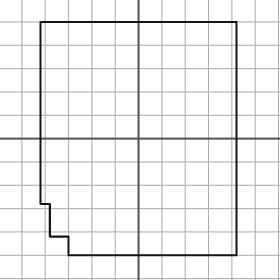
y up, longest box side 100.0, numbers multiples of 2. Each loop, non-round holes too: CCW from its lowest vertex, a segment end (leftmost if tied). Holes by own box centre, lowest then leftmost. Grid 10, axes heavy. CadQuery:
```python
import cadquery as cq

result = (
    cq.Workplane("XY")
    .moveTo(-30.0, -50.0)
    .lineTo(42.0, -50.0)
    .lineTo(42.0, 50.0)
    .lineTo(-42.0, 50.0)
    .lineTo(-42.0, -28.0)
    .lineTo(-38.0, -28.0)
    .lineTo(-38.0, -42.0)
    .lineTo(-30.0, -42.0)
    .close()
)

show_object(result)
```